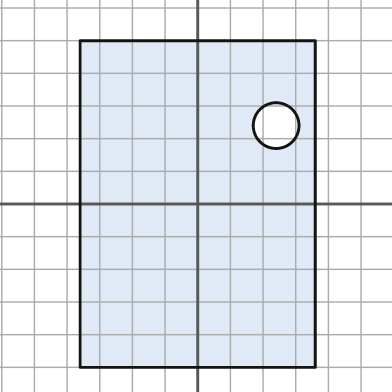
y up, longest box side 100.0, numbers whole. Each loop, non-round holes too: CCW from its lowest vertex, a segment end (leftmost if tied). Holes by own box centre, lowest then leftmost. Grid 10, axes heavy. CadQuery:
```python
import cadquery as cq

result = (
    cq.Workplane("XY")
    .moveTo(-36.0, -50.0)
    .lineTo(36.0, -50.0)
    .lineTo(36.0, 50.0)
    .lineTo(-36.0, 50.0)
    .close()
    .moveTo(24.0, 24.0)
    .circle(7.0)
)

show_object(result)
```